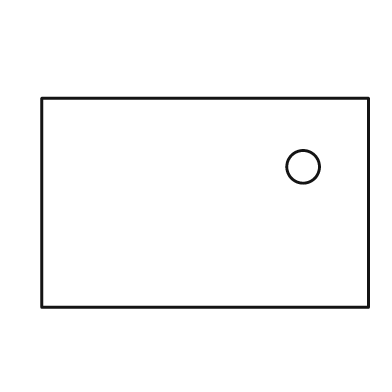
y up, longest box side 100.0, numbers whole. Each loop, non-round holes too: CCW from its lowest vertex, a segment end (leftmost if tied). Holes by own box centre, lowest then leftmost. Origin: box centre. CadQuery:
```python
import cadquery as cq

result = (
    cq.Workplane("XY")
    .moveTo(-50.0, -32.0)
    .lineTo(50.0, -32.0)
    .lineTo(50.0, 32.0)
    .lineTo(-50.0, 32.0)
    .close()
    .moveTo(30.0, 11.0)
    .circle(5.0)
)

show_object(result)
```